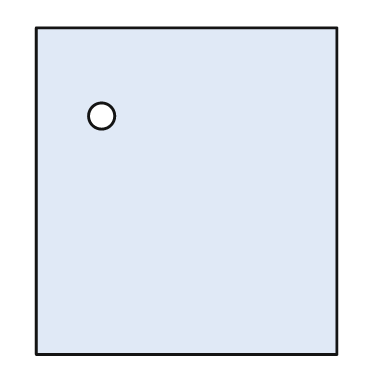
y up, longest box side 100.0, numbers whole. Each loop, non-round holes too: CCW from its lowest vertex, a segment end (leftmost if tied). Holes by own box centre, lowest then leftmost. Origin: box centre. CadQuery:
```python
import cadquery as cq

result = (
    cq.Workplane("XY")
    .moveTo(-46.0, -50.0)
    .lineTo(46.0, -50.0)
    .lineTo(46.0, 50.0)
    .lineTo(-46.0, 50.0)
    .close()
    .moveTo(-26.0, 23.0)
    .circle(4.0)
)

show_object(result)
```